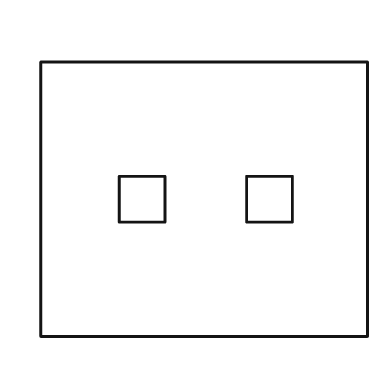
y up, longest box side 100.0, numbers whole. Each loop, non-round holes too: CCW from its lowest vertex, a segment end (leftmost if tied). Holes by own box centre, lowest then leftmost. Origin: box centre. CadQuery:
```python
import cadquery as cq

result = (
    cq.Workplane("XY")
    .moveTo(-50.0, -42.0)
    .lineTo(50.0, -42.0)
    .lineTo(50.0, 42.0)
    .lineTo(-50.0, 42.0)
    .close()
    .moveTo(-26.0, -7.0)
    .lineTo(-12.0, -7.0)
    .lineTo(-12.0, 7.0)
    .lineTo(-26.0, 7.0)
    .close()
    .moveTo(13.0, -7.0)
    .lineTo(27.0, -7.0)
    .lineTo(27.0, 7.0)
    .lineTo(13.0, 7.0)
    .close()
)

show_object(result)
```